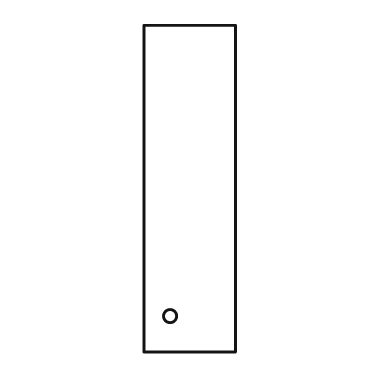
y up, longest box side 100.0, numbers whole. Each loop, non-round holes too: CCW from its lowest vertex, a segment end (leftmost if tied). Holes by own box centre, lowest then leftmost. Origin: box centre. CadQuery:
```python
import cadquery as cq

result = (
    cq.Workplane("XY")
    .moveTo(-14.0, -50.0)
    .lineTo(14.0, -50.0)
    .lineTo(14.0, 50.0)
    .lineTo(-14.0, 50.0)
    .close()
    .moveTo(-6.0, -39.0)
    .circle(2.0)
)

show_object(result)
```